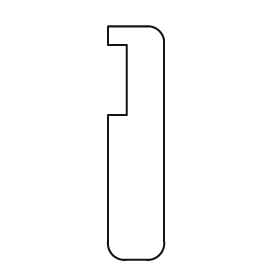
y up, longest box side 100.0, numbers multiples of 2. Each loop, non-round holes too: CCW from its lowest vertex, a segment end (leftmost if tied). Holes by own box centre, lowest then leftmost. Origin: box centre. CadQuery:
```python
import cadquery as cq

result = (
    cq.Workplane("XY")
    .moveTo(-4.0, -50.0)
    .lineTo(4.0, -50.0)
    .threePointArc((10.0, -48.0), (12.0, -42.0))
    .lineTo(12.0, 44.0)
    .threePointArc((10.0, 48.0), (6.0, 50.0))
    .lineTo(-12.0, 50.0)
    .lineTo(-12.0, 42.0)
    .lineTo(-4.0, 42.0)
    .lineTo(-4.0, 12.0)
    .lineTo(-12.0, 12.0)
    .lineTo(-12.0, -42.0)
    .threePointArc((-10.0, -48.0), (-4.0, -50.0))
    .close()
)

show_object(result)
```